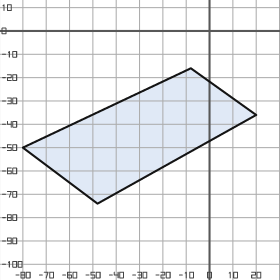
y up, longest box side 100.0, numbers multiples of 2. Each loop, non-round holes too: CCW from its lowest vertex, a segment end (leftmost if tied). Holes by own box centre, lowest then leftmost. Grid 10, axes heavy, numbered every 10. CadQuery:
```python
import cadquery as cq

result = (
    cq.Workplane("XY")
    .moveTo(-48.0, -74.0)
    .lineTo(20.0, -36.0)
    .lineTo(-8.0, -16.0)
    .lineTo(-80.0, -50.0)
    .close()
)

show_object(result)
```